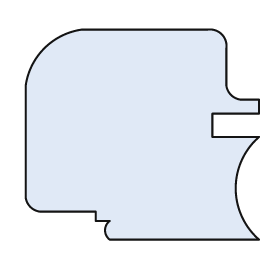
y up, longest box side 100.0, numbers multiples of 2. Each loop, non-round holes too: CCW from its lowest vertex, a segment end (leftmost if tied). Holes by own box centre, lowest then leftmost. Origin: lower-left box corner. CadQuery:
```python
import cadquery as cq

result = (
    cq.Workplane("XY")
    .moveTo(36.0, 0.0)
    .lineTo(100.0, 0.0)
    .threePointArc((90.0, 22.0), (100.0, 44.0))
    .lineTo(80.0, 44.0)
    .lineTo(80.0, 54.0)
    .lineTo(100.0, 54.0)
    .lineTo(100.0, 60.0)
    .lineTo(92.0, 60.0)
    .threePointArc((88.0, 62.0), (86.0, 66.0))
    .lineTo(86.0, 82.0)
    .threePointArc((84.0, 88.0), (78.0, 90.0))
    .lineTo(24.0, 90.0)
    .threePointArc((8.0, 82.0), (0.0, 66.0))
    .lineTo(0.0, 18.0)
    .threePointArc((2.0, 14.0), (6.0, 12.0))
    .lineTo(30.0, 12.0)
    .lineTo(30.0, 8.0)
    .lineTo(36.0, 8.0)
    .threePointArc((34.0, 4.0), (36.0, 0.0))
    .close()
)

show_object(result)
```